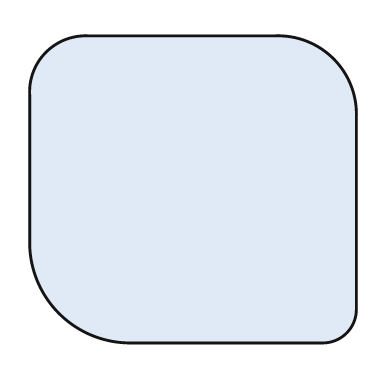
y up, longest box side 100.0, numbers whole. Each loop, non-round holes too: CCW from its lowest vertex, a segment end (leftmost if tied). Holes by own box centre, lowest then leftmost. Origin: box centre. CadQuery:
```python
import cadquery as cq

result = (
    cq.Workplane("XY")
    .moveTo(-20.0, -47.0)
    .lineTo(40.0, -47.0)
    .threePointArc((47.0, -44.0), (50.0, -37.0))
    .lineTo(50.0, 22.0)
    .threePointArc((43.0, 40.0), (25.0, 47.0))
    .lineTo(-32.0, 47.0)
    .threePointArc((-45.0, 42.0), (-50.0, 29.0))
    .lineTo(-50.0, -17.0)
    .threePointArc((-41.0, -38.0), (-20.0, -47.0))
    .close()
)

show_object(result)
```